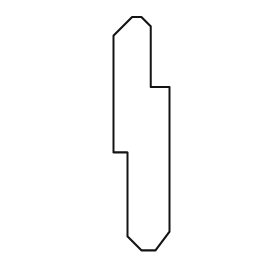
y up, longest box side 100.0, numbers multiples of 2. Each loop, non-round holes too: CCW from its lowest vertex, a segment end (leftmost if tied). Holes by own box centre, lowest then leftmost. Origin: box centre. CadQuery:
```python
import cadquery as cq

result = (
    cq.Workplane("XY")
    .moveTo(0.0, -50.0)
    .lineTo(6.0, -50.0)
    .lineTo(12.0, -42.0)
    .lineTo(12.0, 20.0)
    .lineTo(4.0, 20.0)
    .lineTo(4.0, 46.0)
    .lineTo(0.0, 50.0)
    .lineTo(-4.0, 50.0)
    .lineTo(-12.0, 42.0)
    .lineTo(-12.0, -8.0)
    .lineTo(-6.0, -8.0)
    .lineTo(-6.0, -44.0)
    .close()
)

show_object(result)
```